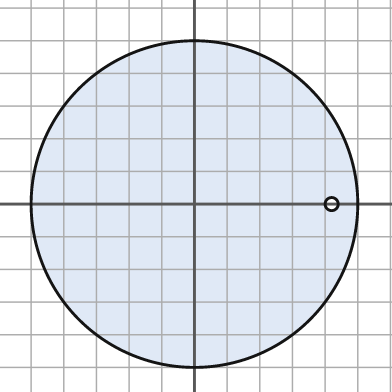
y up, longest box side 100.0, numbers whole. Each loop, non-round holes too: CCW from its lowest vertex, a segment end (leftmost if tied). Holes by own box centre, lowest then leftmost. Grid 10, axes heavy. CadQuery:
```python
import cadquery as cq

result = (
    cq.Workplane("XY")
    .moveTo(0.0, 0.0)
    .circle(50.0)
    .moveTo(42.0, 0.0)
    .circle(2.0)
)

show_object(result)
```